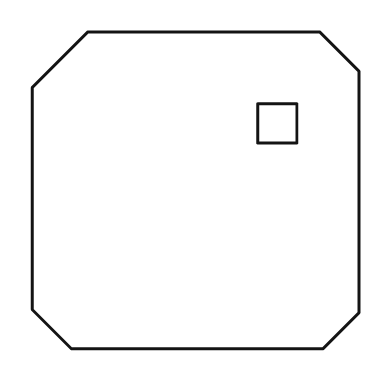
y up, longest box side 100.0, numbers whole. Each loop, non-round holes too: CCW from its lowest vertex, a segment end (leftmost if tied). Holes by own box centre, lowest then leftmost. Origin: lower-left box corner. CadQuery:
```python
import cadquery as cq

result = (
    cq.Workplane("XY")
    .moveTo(12.0, 0.0)
    .lineTo(89.0, 0.0)
    .lineTo(100.0, 11.0)
    .lineTo(100.0, 85.0)
    .lineTo(88.0, 97.0)
    .lineTo(17.0, 97.0)
    .lineTo(0.0, 80.0)
    .lineTo(0.0, 12.0)
    .close()
    .moveTo(69.0, 63.0)
    .lineTo(81.0, 63.0)
    .lineTo(81.0, 75.0)
    .lineTo(69.0, 75.0)
    .close()
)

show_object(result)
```